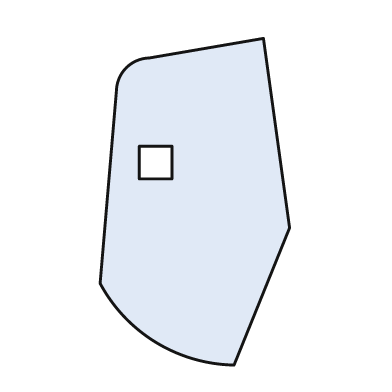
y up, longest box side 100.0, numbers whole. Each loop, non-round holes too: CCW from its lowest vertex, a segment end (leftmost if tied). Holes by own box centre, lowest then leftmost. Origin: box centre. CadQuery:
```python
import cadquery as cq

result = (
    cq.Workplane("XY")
    .moveTo(12.0, -50.0)
    .lineTo(29.0, -8.0)
    .lineTo(21.0, 50.0)
    .lineTo(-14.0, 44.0)
    .threePointArc((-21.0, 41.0), (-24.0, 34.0))
    .lineTo(-29.0, -25.0)
    .threePointArc((-12.0, -43.0), (12.0, -50.0))
    .close()
    .moveTo(-17.0, 7.0)
    .lineTo(-7.0, 7.0)
    .lineTo(-7.0, 17.0)
    .lineTo(-17.0, 17.0)
    .close()
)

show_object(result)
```